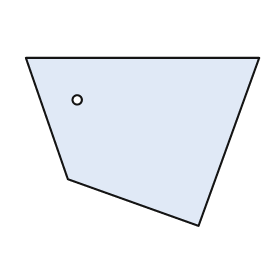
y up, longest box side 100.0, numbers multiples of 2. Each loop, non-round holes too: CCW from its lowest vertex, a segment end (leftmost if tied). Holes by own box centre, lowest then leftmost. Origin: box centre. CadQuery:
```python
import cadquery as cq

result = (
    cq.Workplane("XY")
    .moveTo(24.0, -36.0)
    .lineTo(50.0, 36.0)
    .lineTo(-50.0, 36.0)
    .lineTo(-32.0, -16.0)
    .close()
    .moveTo(-28.0, 18.0)
    .circle(2.0)
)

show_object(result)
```